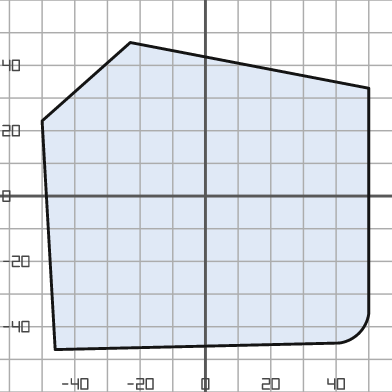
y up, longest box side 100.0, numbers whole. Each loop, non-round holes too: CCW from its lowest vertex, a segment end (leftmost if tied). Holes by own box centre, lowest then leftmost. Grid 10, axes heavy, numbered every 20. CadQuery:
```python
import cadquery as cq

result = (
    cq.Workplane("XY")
    .moveTo(-46.0, -47.0)
    .lineTo(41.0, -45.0)
    .threePointArc((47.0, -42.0), (50.0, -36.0))
    .lineTo(50.0, 33.0)
    .lineTo(-23.0, 47.0)
    .lineTo(-50.0, 23.0)
    .close()
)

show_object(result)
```